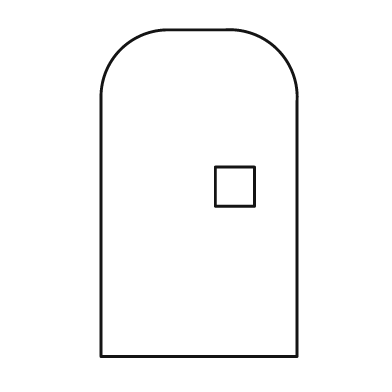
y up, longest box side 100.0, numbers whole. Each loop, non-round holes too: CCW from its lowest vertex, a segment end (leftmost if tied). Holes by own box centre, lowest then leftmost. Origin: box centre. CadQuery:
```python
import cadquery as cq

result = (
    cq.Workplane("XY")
    .moveTo(-30.0, -50.0)
    .lineTo(30.0, -50.0)
    .lineTo(30.0, 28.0)
    .threePointArc((24.0, 44.0), (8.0, 50.0))
    .lineTo(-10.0, 50.0)
    .threePointArc((-24.0, 44.0), (-30.0, 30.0))
    .close()
    .moveTo(5.0, -4.0)
    .lineTo(17.0, -4.0)
    .lineTo(17.0, 8.0)
    .lineTo(5.0, 8.0)
    .close()
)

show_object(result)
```